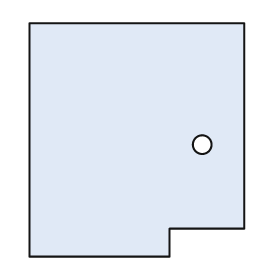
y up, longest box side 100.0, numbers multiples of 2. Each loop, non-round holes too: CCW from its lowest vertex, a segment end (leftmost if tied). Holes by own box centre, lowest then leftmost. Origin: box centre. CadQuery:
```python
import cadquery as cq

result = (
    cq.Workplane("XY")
    .moveTo(-46.0, -50.0)
    .lineTo(14.0, -50.0)
    .lineTo(14.0, -38.0)
    .lineTo(46.0, -38.0)
    .lineTo(46.0, 50.0)
    .lineTo(-46.0, 50.0)
    .close()
    .moveTo(28.0, -2.0)
    .circle(4.0)
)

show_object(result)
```